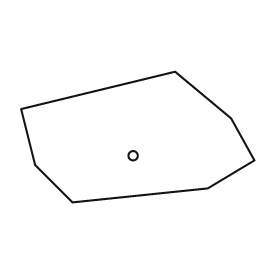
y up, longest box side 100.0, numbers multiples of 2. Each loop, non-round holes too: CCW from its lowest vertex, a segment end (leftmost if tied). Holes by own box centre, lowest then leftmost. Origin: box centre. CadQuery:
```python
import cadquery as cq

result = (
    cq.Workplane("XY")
    .moveTo(-28.0, -28.0)
    .lineTo(30.0, -22.0)
    .lineTo(50.0, -10.0)
    .lineTo(40.0, 8.0)
    .lineTo(16.0, 28.0)
    .lineTo(-50.0, 12.0)
    .lineTo(-44.0, -12.0)
    .close()
    .moveTo(-2.0, -8.0)
    .circle(2.0)
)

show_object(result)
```